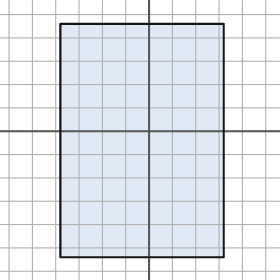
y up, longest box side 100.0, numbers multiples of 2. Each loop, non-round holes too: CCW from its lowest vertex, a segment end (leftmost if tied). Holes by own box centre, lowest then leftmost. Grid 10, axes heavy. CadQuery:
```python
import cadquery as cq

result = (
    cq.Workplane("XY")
    .moveTo(-38.0, -54.0)
    .lineTo(32.0, -54.0)
    .lineTo(32.0, 46.0)
    .lineTo(-38.0, 46.0)
    .close()
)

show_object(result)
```